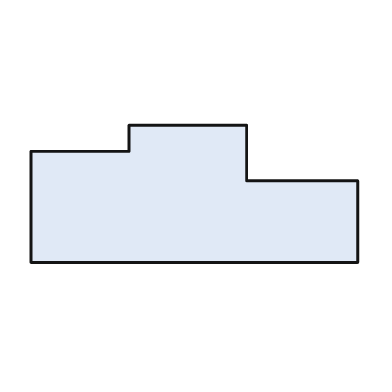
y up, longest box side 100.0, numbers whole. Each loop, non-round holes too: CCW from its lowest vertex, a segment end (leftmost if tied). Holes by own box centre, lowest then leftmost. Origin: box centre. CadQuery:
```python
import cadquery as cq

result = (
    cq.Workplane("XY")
    .moveTo(-50.0, -21.0)
    .lineTo(50.0, -21.0)
    .lineTo(50.0, 4.0)
    .lineTo(16.0, 4.0)
    .lineTo(16.0, 21.0)
    .lineTo(-20.0, 21.0)
    .lineTo(-20.0, 13.0)
    .lineTo(-50.0, 13.0)
    .close()
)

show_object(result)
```